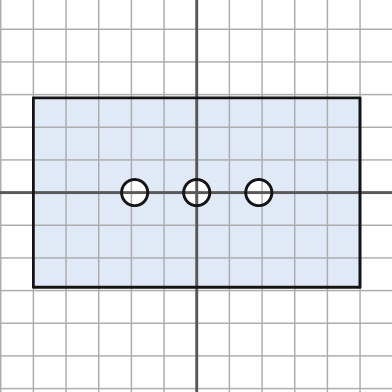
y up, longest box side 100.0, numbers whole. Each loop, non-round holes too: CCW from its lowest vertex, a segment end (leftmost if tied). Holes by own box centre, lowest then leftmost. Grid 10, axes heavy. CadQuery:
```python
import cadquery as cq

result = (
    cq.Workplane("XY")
    .moveTo(-50.0, -29.0)
    .lineTo(50.0, -29.0)
    .lineTo(50.0, 29.0)
    .lineTo(-50.0, 29.0)
    .close()
    .moveTo(-19.0, 0.0)
    .circle(4.0)
    .moveTo(0.0, 0.0)
    .circle(4.0)
    .moveTo(19.0, 0.0)
    .circle(4.0)
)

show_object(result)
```